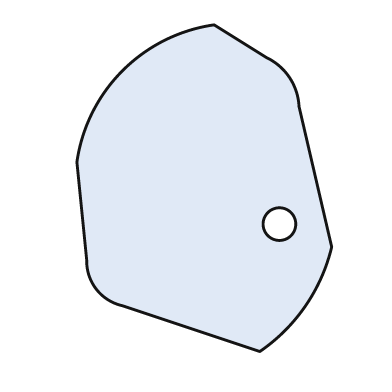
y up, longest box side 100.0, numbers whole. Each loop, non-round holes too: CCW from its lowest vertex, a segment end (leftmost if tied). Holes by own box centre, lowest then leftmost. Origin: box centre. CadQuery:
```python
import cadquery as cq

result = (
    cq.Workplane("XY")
    .moveTo(17.0, -50.0)
    .threePointArc((31.0, -36.0), (39.0, -18.0))
    .lineTo(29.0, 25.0)
    .threePointArc((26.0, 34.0), (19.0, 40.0))
    .lineTo(3.0, 50.0)
    .threePointArc((-25.0, 36.0), (-39.0, 8.0))
    .lineTo(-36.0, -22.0)
    .threePointArc((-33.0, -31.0), (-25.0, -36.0))
    .close()
    .moveTo(23.0, -11.0)
    .circle(5.0)
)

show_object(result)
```